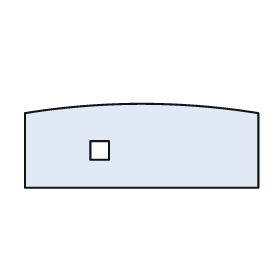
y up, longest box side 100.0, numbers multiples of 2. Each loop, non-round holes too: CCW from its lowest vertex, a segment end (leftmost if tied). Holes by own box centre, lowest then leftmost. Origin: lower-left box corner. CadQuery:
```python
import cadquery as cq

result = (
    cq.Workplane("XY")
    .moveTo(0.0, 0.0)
    .lineTo(100.0, 0.0)
    .lineTo(100.0, 32.0)
    .threePointArc((50.0, 36.0), (0.0, 32.0))
    .close()
    .moveTo(28.0, 12.0)
    .lineTo(36.0, 12.0)
    .lineTo(36.0, 20.0)
    .lineTo(28.0, 20.0)
    .close()
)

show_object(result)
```